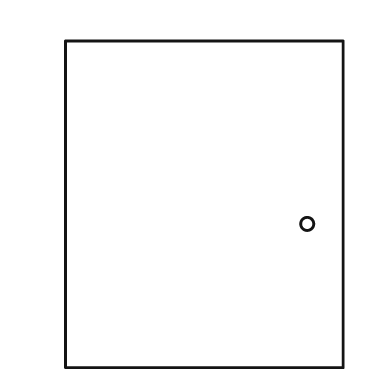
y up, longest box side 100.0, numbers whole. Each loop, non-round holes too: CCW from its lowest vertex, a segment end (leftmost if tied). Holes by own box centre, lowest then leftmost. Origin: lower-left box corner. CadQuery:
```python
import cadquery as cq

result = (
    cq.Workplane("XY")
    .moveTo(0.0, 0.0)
    .lineTo(85.0, 0.0)
    .lineTo(85.0, 100.0)
    .lineTo(0.0, 100.0)
    .close()
    .moveTo(74.0, 44.0)
    .circle(2.0)
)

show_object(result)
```